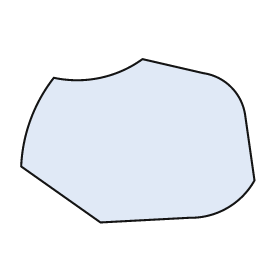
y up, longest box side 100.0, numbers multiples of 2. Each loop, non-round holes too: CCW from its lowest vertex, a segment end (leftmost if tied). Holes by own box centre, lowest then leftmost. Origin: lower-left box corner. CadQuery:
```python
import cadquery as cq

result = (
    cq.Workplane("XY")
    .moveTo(34.0, 0.0)
    .lineTo(72.0, 2.0)
    .threePointArc((88.0, 6.0), (100.0, 18.0))
    .lineTo(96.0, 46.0)
    .threePointArc((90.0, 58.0), (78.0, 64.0))
    .lineTo(52.0, 70.0)
    .threePointArc((34.0, 62.0), (14.0, 62.0))
    .threePointArc((4.0, 44.0), (0.0, 24.0))
    .close()
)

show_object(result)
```